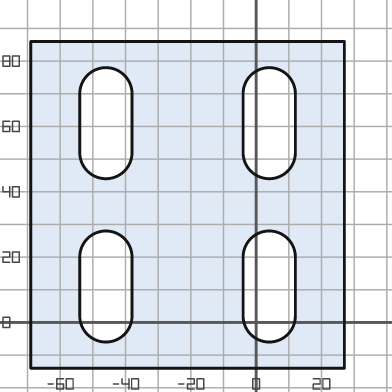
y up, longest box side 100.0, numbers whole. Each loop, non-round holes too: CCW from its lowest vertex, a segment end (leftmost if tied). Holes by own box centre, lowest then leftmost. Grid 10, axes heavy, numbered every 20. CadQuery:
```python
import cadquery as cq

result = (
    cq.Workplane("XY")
    .moveTo(-69.0, -14.0)
    .lineTo(27.0, -14.0)
    .lineTo(27.0, 86.0)
    .lineTo(-69.0, 86.0)
    .close()
    .moveTo(-54.0, 2.0)
    .threePointArc((-46.0, -6.0), (-38.0, 2.0))
    .lineTo(-38.0, 20.0)
    .threePointArc((-46.0, 28.0), (-54.0, 20.0))
    .close()
    .moveTo(-4.0, 2.0)
    .threePointArc((4.0, -6.0), (12.0, 2.0))
    .lineTo(12.0, 20.0)
    .threePointArc((4.0, 28.0), (-4.0, 20.0))
    .close()
    .moveTo(-54.0, 52.0)
    .threePointArc((-46.0, 44.0), (-38.0, 52.0))
    .lineTo(-38.0, 70.0)
    .threePointArc((-46.0, 78.0), (-54.0, 70.0))
    .close()
    .moveTo(-4.0, 52.0)
    .threePointArc((4.0, 44.0), (12.0, 52.0))
    .lineTo(12.0, 70.0)
    .threePointArc((4.0, 78.0), (-4.0, 70.0))
    .close()
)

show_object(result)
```